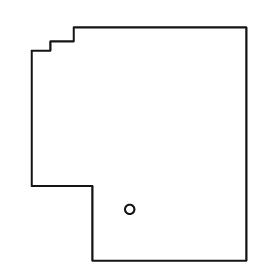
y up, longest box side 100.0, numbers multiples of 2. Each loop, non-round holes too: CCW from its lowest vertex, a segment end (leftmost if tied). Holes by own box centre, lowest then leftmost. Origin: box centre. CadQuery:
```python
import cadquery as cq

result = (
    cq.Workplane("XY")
    .moveTo(-20.0, -50.0)
    .lineTo(46.0, -50.0)
    .lineTo(46.0, 50.0)
    .lineTo(-28.0, 50.0)
    .lineTo(-28.0, 44.0)
    .lineTo(-38.0, 44.0)
    .lineTo(-38.0, 40.0)
    .lineTo(-46.0, 40.0)
    .lineTo(-46.0, -18.0)
    .lineTo(-20.0, -18.0)
    .close()
    .moveTo(-4.0, -28.0)
    .circle(2.0)
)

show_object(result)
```